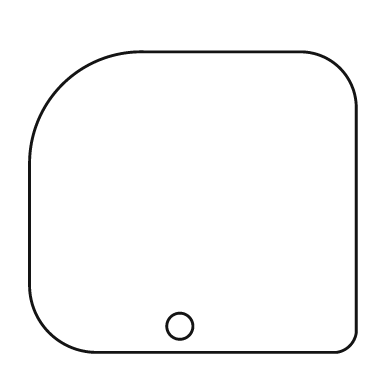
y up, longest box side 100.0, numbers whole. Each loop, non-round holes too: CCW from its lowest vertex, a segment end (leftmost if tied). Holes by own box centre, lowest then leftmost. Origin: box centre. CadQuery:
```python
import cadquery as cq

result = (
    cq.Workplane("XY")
    .moveTo(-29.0, -46.0)
    .lineTo(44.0, -46.0)
    .threePointArc((48.0, -44.0), (50.0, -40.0))
    .lineTo(50.0, 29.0)
    .threePointArc((45.0, 41.0), (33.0, 46.0))
    .lineTo(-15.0, 46.0)
    .threePointArc((-40.0, 36.0), (-50.0, 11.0))
    .lineTo(-50.0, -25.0)
    .threePointArc((-44.0, -40.0), (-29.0, -46.0))
    .close()
    .moveTo(-4.0, -38.0)
    .circle(4.0)
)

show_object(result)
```